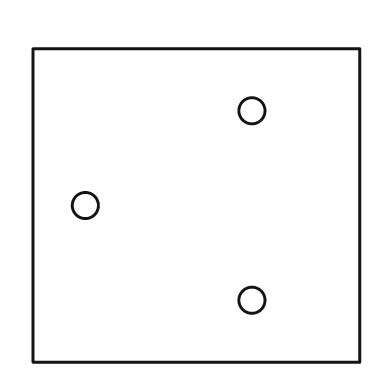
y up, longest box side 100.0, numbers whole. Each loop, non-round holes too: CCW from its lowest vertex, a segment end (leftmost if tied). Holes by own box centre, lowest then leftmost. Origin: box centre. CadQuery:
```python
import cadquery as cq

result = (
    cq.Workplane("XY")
    .moveTo(-50.0, -48.0)
    .lineTo(50.0, -48.0)
    .lineTo(50.0, 48.0)
    .lineTo(-50.0, 48.0)
    .close()
    .moveTo(17.0, -29.0)
    .circle(4.0)
    .moveTo(-34.0, 0.0)
    .circle(4.0)
    .moveTo(17.0, 29.0)
    .circle(4.0)
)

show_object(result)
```